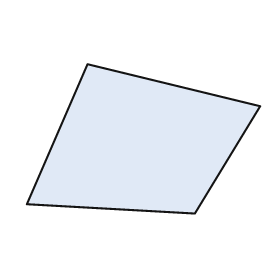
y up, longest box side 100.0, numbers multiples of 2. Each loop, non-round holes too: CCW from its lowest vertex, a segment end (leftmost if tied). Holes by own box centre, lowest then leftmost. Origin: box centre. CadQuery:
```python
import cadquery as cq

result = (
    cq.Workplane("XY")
    .moveTo(22.0, -32.0)
    .lineTo(50.0, 14.0)
    .lineTo(-24.0, 32.0)
    .lineTo(-50.0, -28.0)
    .close()
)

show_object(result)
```